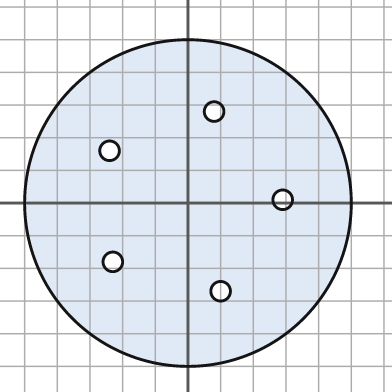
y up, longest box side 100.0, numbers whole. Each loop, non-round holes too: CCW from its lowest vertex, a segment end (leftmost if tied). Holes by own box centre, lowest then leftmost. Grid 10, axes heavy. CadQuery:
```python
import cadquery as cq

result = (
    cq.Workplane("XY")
    .moveTo(0.0, 0.0)
    .circle(50.0)
    .moveTo(10.0, -27.0)
    .circle(3.0)
    .moveTo(-23.0, -18.0)
    .circle(3.0)
    .moveTo(29.0, 1.0)
    .circle(3.0)
    .moveTo(-24.0, 16.0)
    .circle(3.0)
    .moveTo(8.0, 28.0)
    .circle(3.0)
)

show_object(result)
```